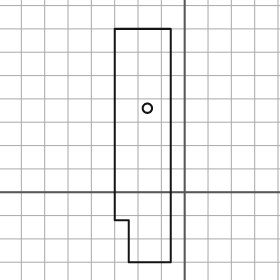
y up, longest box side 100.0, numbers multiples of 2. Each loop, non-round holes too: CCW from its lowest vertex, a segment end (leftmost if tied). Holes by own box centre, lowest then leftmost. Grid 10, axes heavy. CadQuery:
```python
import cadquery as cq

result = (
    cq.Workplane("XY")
    .moveTo(-24.0, -30.0)
    .lineTo(-6.0, -30.0)
    .lineTo(-6.0, 70.0)
    .lineTo(-30.0, 70.0)
    .lineTo(-30.0, -12.0)
    .lineTo(-24.0, -12.0)
    .close()
    .moveTo(-16.0, 36.0)
    .circle(2.0)
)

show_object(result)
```